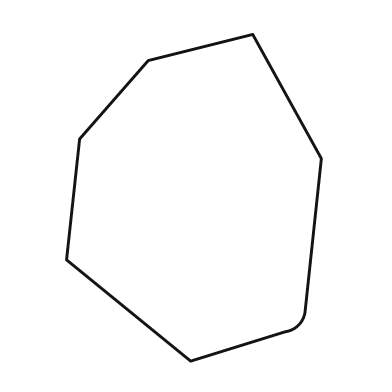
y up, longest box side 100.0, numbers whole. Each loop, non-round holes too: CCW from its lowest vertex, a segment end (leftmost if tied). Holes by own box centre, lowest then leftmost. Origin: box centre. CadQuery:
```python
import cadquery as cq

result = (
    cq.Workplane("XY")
    .moveTo(-1.0, -50.0)
    .lineTo(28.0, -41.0)
    .threePointArc((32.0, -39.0), (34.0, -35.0))
    .lineTo(39.0, 12.0)
    .lineTo(18.0, 50.0)
    .lineTo(-14.0, 42.0)
    .lineTo(-35.0, 18.0)
    .lineTo(-39.0, -19.0)
    .close()
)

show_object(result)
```